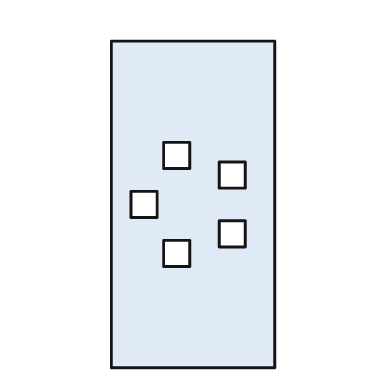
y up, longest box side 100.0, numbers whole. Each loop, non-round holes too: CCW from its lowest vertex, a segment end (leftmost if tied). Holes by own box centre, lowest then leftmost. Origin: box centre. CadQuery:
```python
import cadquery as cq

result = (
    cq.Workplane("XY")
    .moveTo(-25.0, -50.0)
    .lineTo(25.0, -50.0)
    .lineTo(25.0, 50.0)
    .lineTo(-25.0, 50.0)
    .close()
    .moveTo(-9.0, -19.0)
    .lineTo(-1.0, -19.0)
    .lineTo(-1.0, -11.0)
    .lineTo(-9.0, -11.0)
    .close()
    .moveTo(8.0, -13.0)
    .lineTo(16.0, -13.0)
    .lineTo(16.0, -5.0)
    .lineTo(8.0, -5.0)
    .close()
    .moveTo(-19.0, -4.0)
    .lineTo(-11.0, -4.0)
    .lineTo(-11.0, 4.0)
    .lineTo(-19.0, 4.0)
    .close()
    .moveTo(8.0, 5.0)
    .lineTo(16.0, 5.0)
    .lineTo(16.0, 13.0)
    .lineTo(8.0, 13.0)
    .close()
    .moveTo(-9.0, 11.0)
    .lineTo(-1.0, 11.0)
    .lineTo(-1.0, 19.0)
    .lineTo(-9.0, 19.0)
    .close()
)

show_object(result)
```